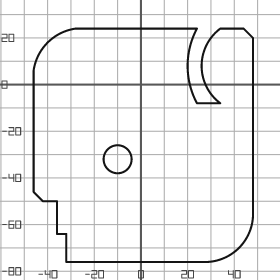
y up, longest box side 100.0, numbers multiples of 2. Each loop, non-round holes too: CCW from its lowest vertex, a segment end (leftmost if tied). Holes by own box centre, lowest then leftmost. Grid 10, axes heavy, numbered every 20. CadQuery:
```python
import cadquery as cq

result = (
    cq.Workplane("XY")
    .moveTo(-32.0, -76.0)
    .lineTo(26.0, -76.0)
    .threePointArc((42.0, -70.0), (48.0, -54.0))
    .lineTo(48.0, 20.0)
    .lineTo(44.0, 24.0)
    .lineTo(34.0, 24.0)
    .threePointArc((26.0, 8.0), (34.0, -8.0))
    .lineTo(24.0, -8.0)
    .threePointArc((20.0, 8.0), (24.0, 24.0))
    .lineTo(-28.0, 24.0)
    .threePointArc((-40.0, 18.0), (-46.0, 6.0))
    .lineTo(-46.0, -46.0)
    .lineTo(-42.0, -50.0)
    .lineTo(-36.0, -50.0)
    .lineTo(-36.0, -64.0)
    .lineTo(-32.0, -64.0)
    .close()
    .moveTo(-10.0, -32.0)
    .circle(6.0)
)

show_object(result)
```